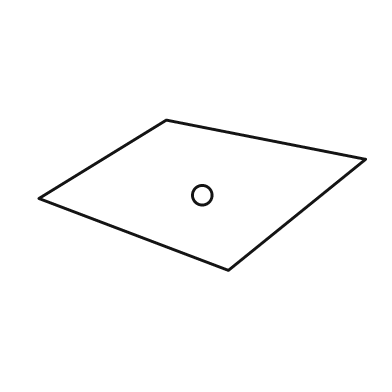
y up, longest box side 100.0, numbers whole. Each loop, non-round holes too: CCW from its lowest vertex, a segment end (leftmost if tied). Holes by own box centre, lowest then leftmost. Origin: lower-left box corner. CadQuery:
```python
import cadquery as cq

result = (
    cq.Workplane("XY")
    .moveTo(58.0, 0.0)
    .lineTo(100.0, 34.0)
    .lineTo(39.0, 46.0)
    .lineTo(0.0, 22.0)
    .close()
    .moveTo(50.0, 23.0)
    .circle(3.0)
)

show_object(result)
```